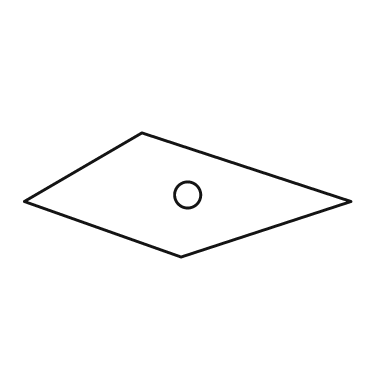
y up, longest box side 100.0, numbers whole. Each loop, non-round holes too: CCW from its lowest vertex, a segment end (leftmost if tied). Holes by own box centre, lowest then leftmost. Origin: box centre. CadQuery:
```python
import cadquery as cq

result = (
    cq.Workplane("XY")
    .moveTo(-2.0, -19.0)
    .lineTo(50.0, -2.0)
    .lineTo(-14.0, 19.0)
    .lineTo(-50.0, -2.0)
    .close()
    .moveTo(0.0, 0.0)
    .circle(4.0)
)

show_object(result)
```